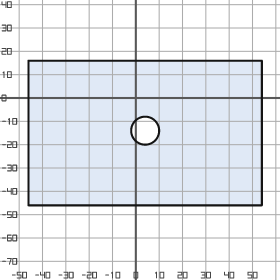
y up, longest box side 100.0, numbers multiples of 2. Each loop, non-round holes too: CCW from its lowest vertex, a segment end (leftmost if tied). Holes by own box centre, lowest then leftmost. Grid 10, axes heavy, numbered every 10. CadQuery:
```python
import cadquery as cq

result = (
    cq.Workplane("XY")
    .moveTo(-46.0, -46.0)
    .lineTo(54.0, -46.0)
    .lineTo(54.0, 16.0)
    .lineTo(-46.0, 16.0)
    .close()
    .moveTo(4.0, -14.0)
    .circle(6.0)
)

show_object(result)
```